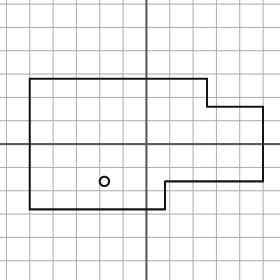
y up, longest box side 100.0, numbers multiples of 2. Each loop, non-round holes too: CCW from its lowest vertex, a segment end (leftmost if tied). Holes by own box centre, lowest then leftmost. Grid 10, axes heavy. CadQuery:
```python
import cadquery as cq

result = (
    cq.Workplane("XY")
    .moveTo(-50.0, -28.0)
    .lineTo(8.0, -28.0)
    .lineTo(8.0, -16.0)
    .lineTo(50.0, -16.0)
    .lineTo(50.0, 16.0)
    .lineTo(26.0, 16.0)
    .lineTo(26.0, 28.0)
    .lineTo(-50.0, 28.0)
    .close()
    .moveTo(-18.0, -16.0)
    .circle(2.0)
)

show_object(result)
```